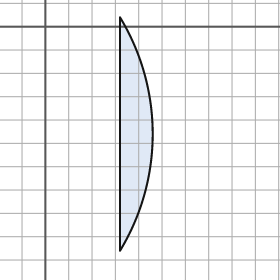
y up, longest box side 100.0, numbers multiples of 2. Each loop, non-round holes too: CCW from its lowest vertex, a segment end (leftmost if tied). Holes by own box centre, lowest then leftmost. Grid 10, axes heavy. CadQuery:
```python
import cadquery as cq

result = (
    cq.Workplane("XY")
    .moveTo(32.0, -96.0)
    .threePointArc((46.0, -46.0), (32.0, 4.0))
    .close()
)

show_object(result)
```